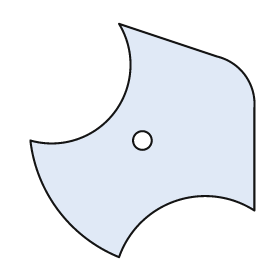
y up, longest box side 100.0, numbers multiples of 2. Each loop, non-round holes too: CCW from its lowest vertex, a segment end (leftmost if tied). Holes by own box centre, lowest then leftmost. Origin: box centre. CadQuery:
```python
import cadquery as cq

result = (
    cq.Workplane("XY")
    .moveTo(-10.0, -50.0)
    .threePointArc((14.0, -26.0), (48.0, -30.0))
    .lineTo(48.0, 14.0)
    .threePointArc((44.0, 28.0), (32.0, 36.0))
    .lineTo(-10.0, 50.0)
    .threePointArc((-12.0, 12.0), (-48.0, 0.0))
    .threePointArc((-36.0, -30.0), (-10.0, -50.0))
    .close()
    .moveTo(0.0, 0.0)
    .circle(4.0)
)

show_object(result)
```